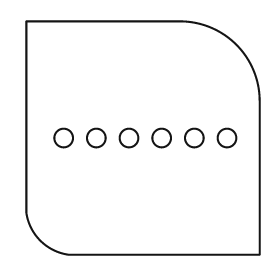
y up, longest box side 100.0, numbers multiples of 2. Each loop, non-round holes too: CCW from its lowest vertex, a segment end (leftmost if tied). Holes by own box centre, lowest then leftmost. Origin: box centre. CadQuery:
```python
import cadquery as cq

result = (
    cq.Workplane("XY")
    .moveTo(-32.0, -50.0)
    .lineTo(50.0, -50.0)
    .lineTo(50.0, 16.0)
    .threePointArc((40.0, 40.0), (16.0, 50.0))
    .lineTo(-50.0, 50.0)
    .lineTo(-50.0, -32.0)
    .threePointArc((-44.0, -44.0), (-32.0, -50.0))
    .close()
    .moveTo(-34.0, 0.0)
    .circle(4.0)
    .moveTo(-20.0, 0.0)
    .circle(4.0)
    .moveTo(-6.0, 0.0)
    .circle(4.0)
    .moveTo(8.0, 0.0)
    .circle(4.0)
    .moveTo(22.0, 0.0)
    .circle(4.0)
    .moveTo(36.0, 0.0)
    .circle(4.0)
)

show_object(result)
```